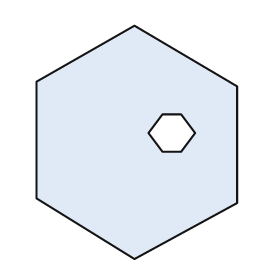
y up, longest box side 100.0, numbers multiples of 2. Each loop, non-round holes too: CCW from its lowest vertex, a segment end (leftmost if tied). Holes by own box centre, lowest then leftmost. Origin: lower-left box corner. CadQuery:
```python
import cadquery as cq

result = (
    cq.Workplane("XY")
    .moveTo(42.0, 0.0)
    .lineTo(86.0, 24.0)
    .lineTo(86.0, 74.0)
    .lineTo(42.0, 100.0)
    .lineTo(0.0, 76.0)
    .lineTo(0.0, 26.0)
    .close()
    .moveTo(54.0, 46.0)
    .lineTo(62.0, 46.0)
    .lineTo(68.0, 54.0)
    .lineTo(62.0, 62.0)
    .lineTo(54.0, 62.0)
    .lineTo(48.0, 54.0)
    .close()
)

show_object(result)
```